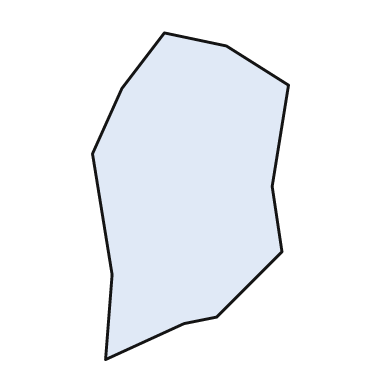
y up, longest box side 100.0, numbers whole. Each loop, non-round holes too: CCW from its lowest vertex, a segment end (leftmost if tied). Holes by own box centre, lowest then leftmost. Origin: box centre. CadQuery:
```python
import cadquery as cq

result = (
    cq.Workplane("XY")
    .moveTo(-26.0, -50.0)
    .lineTo(-2.0, -39.0)
    .lineTo(8.0, -37.0)
    .lineTo(28.0, -17.0)
    .lineTo(25.0, 3.0)
    .lineTo(30.0, 34.0)
    .lineTo(11.0, 46.0)
    .lineTo(-8.0, 50.0)
    .lineTo(-21.0, 33.0)
    .lineTo(-30.0, 13.0)
    .lineTo(-24.0, -24.0)
    .close()
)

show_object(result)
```